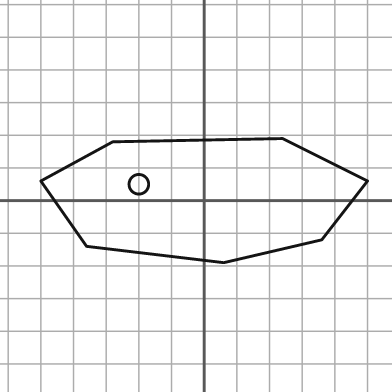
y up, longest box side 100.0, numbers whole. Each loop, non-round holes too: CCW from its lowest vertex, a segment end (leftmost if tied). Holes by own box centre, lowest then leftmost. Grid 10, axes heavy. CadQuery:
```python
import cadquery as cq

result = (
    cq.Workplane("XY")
    .moveTo(6.0, -19.0)
    .lineTo(36.0, -12.0)
    .lineTo(50.0, 6.0)
    .lineTo(24.0, 19.0)
    .lineTo(-28.0, 18.0)
    .lineTo(-50.0, 6.0)
    .lineTo(-36.0, -14.0)
    .close()
    .moveTo(-20.0, 5.0)
    .circle(3.0)
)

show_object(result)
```